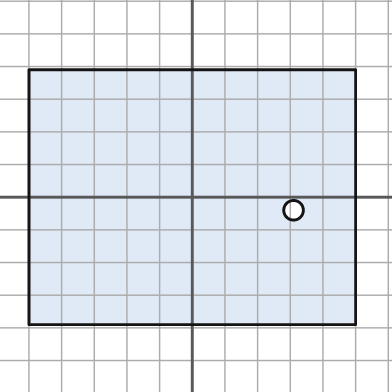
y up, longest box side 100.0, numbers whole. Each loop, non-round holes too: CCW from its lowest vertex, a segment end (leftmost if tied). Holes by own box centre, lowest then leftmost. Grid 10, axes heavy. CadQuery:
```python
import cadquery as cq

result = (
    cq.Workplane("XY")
    .moveTo(-50.0, -39.0)
    .lineTo(50.0, -39.0)
    .lineTo(50.0, 39.0)
    .lineTo(-50.0, 39.0)
    .close()
    .moveTo(31.0, -4.0)
    .circle(3.0)
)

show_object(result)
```